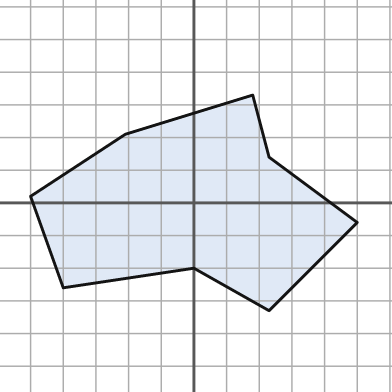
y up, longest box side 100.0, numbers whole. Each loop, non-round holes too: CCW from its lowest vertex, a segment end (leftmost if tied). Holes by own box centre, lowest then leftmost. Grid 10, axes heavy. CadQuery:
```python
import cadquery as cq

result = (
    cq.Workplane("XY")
    .moveTo(23.0, -33.0)
    .lineTo(50.0, -6.0)
    .lineTo(23.0, 14.0)
    .lineTo(18.0, 33.0)
    .lineTo(-21.0, 21.0)
    .lineTo(-50.0, 2.0)
    .lineTo(-40.0, -26.0)
    .lineTo(0.0, -20.0)
    .close()
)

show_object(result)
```